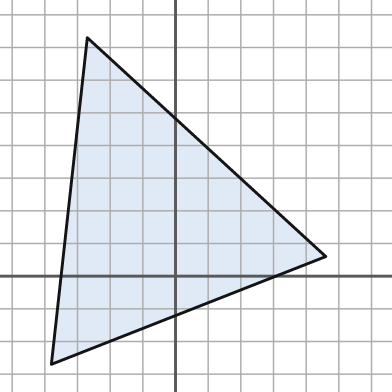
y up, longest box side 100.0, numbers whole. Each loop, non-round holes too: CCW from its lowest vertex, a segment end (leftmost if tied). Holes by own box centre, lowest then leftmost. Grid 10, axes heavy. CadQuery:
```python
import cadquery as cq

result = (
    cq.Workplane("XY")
    .moveTo(-38.0, -27.0)
    .lineTo(46.0, 6.0)
    .lineTo(-27.0, 73.0)
    .close()
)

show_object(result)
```